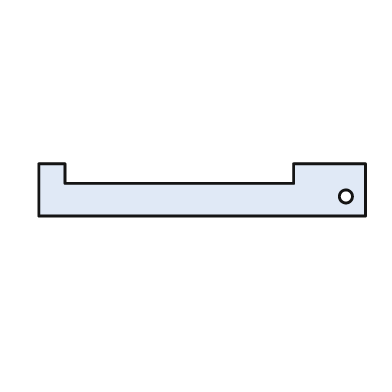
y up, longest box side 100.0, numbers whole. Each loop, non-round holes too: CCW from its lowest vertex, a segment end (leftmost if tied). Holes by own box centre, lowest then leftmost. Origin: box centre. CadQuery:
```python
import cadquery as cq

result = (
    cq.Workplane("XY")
    .moveTo(-50.0, -8.0)
    .lineTo(50.0, -8.0)
    .lineTo(50.0, 8.0)
    .lineTo(28.0, 8.0)
    .lineTo(28.0, 2.0)
    .lineTo(-42.0, 2.0)
    .lineTo(-42.0, 8.0)
    .lineTo(-50.0, 8.0)
    .close()
    .moveTo(44.0, -2.0)
    .circle(2.0)
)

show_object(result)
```